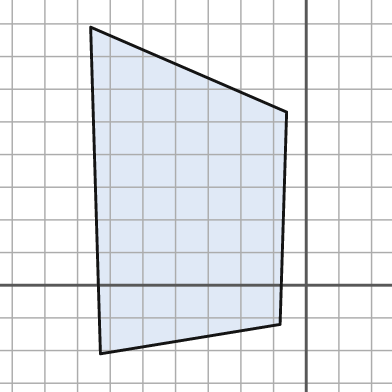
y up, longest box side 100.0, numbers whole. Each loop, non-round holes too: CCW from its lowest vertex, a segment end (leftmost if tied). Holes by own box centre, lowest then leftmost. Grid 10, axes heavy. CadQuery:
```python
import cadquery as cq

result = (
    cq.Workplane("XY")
    .moveTo(-63.0, -21.0)
    .lineTo(-8.0, -12.0)
    .lineTo(-6.0, 53.0)
    .lineTo(-66.0, 79.0)
    .close()
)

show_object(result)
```